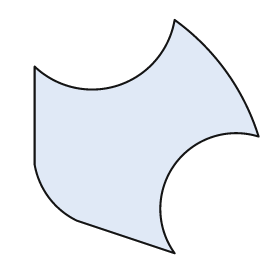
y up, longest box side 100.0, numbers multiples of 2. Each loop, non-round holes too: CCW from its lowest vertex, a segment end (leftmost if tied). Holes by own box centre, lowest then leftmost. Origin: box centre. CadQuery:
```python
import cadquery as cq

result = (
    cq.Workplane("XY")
    .moveTo(12.0, -50.0)
    .threePointArc((12.0, -12.0), (48.0, 0.0))
    .threePointArc((34.0, 28.0), (12.0, 50.0))
    .threePointArc((-12.0, 22.0), (-48.0, 30.0))
    .lineTo(-48.0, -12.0)
    .threePointArc((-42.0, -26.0), (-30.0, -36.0))
    .close()
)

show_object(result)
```